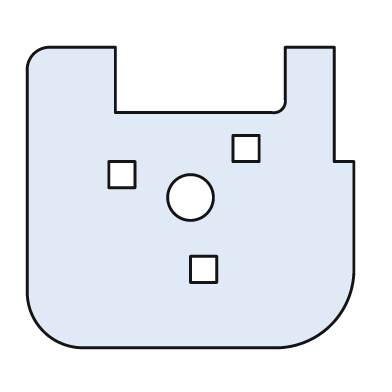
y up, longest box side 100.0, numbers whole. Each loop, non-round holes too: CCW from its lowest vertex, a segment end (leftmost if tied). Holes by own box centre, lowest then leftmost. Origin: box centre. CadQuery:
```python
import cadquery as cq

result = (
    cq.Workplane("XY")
    .moveTo(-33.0, -46.0)
    .lineTo(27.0, -46.0)
    .threePointArc((43.0, -39.0), (50.0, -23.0))
    .lineTo(50.0, 11.0)
    .lineTo(44.0, 11.0)
    .lineTo(44.0, 46.0)
    .lineTo(29.0, 46.0)
    .lineTo(29.0, 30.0)
    .threePointArc((28.0, 27.0), (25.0, 26.0))
    .lineTo(-23.0, 26.0)
    .lineTo(-23.0, 46.0)
    .lineTo(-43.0, 46.0)
    .threePointArc((-48.0, 44.0), (-50.0, 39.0))
    .lineTo(-50.0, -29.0)
    .threePointArc((-45.0, -41.0), (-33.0, -46.0))
    .close()
    .moveTo(0.0, -26.0)
    .lineTo(8.0, -26.0)
    .lineTo(8.0, -18.0)
    .lineTo(0.0, -18.0)
    .close()
    .moveTo(0.0, 0.0)
    .circle(7.0)
    .moveTo(-25.0, 3.0)
    .lineTo(-17.0, 3.0)
    .lineTo(-17.0, 11.0)
    .lineTo(-25.0, 11.0)
    .close()
    .moveTo(13.0, 11.0)
    .lineTo(21.0, 11.0)
    .lineTo(21.0, 19.0)
    .lineTo(13.0, 19.0)
    .close()
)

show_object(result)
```